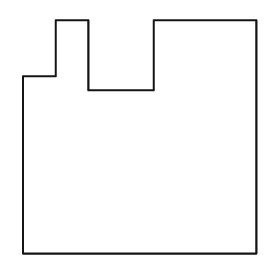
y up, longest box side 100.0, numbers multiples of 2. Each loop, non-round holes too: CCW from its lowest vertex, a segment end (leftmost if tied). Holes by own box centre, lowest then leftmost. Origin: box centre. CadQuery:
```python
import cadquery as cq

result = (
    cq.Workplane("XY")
    .moveTo(-50.0, -50.0)
    .lineTo(50.0, -50.0)
    .lineTo(50.0, 50.0)
    .lineTo(6.0, 50.0)
    .lineTo(6.0, 20.0)
    .lineTo(-22.0, 20.0)
    .lineTo(-22.0, 50.0)
    .lineTo(-36.0, 50.0)
    .lineTo(-36.0, 26.0)
    .lineTo(-50.0, 26.0)
    .close()
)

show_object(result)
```